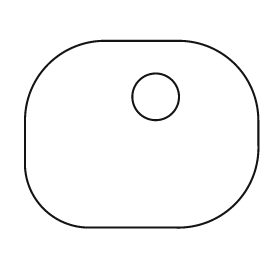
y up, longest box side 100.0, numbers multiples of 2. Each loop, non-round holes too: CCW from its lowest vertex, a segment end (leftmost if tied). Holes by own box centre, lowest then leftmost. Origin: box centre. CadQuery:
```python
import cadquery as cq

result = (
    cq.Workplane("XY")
    .moveTo(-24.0, -40.0)
    .lineTo(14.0, -40.0)
    .threePointArc((40.0, -30.0), (50.0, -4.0))
    .lineTo(50.0, 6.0)
    .threePointArc((40.0, 30.0), (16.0, 40.0))
    .lineTo(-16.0, 40.0)
    .threePointArc((-40.0, 30.0), (-50.0, 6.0))
    .lineTo(-50.0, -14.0)
    .threePointArc((-42.0, -32.0), (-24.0, -40.0))
    .close()
    .moveTo(6.0, 16.0)
    .circle(10.0)
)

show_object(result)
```